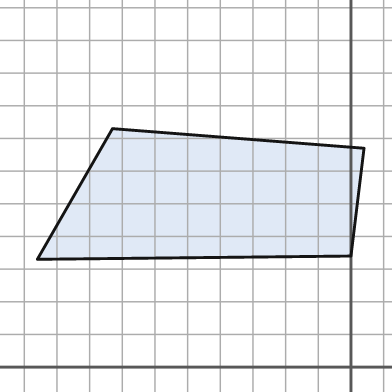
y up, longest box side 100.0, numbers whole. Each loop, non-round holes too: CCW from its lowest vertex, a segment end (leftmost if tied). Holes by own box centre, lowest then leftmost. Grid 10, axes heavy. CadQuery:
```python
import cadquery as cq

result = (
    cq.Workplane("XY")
    .moveTo(-96.0, 33.0)
    .lineTo(0.0, 34.0)
    .lineTo(4.0, 67.0)
    .lineTo(-73.0, 73.0)
    .close()
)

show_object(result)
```